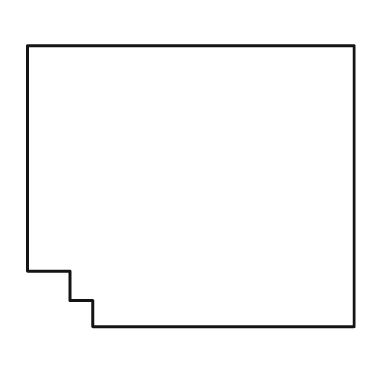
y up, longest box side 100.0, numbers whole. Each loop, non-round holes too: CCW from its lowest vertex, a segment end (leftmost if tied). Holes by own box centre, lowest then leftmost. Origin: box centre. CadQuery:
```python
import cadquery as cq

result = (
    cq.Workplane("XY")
    .moveTo(-30.0, -43.0)
    .lineTo(50.0, -43.0)
    .lineTo(50.0, 43.0)
    .lineTo(-50.0, 43.0)
    .lineTo(-50.0, -26.0)
    .lineTo(-37.0, -26.0)
    .lineTo(-37.0, -35.0)
    .lineTo(-30.0, -35.0)
    .close()
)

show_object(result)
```